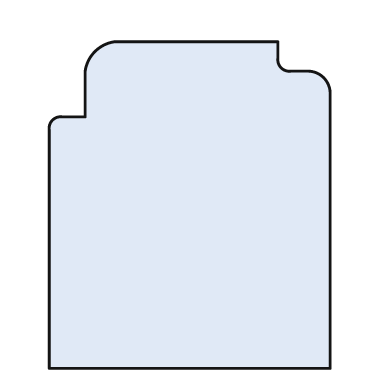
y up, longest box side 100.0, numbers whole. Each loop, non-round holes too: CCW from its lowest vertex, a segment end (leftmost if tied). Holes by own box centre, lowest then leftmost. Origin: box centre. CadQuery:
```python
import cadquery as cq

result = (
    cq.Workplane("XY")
    .moveTo(-43.0, -50.0)
    .lineTo(43.0, -50.0)
    .lineTo(43.0, 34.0)
    .threePointArc((41.0, 39.0), (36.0, 41.0))
    .lineTo(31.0, 41.0)
    .threePointArc((28.0, 42.0), (27.0, 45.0))
    .lineTo(27.0, 50.0)
    .lineTo(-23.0, 50.0)
    .threePointArc((-29.0, 47.0), (-32.0, 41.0))
    .lineTo(-32.0, 27.0)
    .lineTo(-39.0, 27.0)
    .threePointArc((-42.0, 26.0), (-43.0, 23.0))
    .close()
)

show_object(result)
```